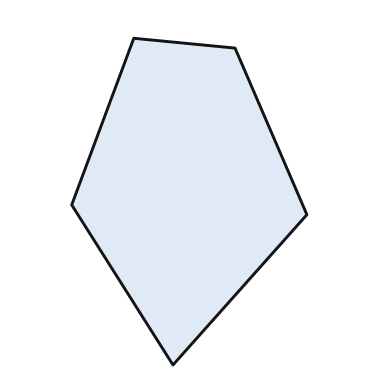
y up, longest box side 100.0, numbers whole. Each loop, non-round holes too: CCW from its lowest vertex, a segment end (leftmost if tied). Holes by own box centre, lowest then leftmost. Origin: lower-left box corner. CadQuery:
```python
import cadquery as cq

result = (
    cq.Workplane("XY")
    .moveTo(31.0, 0.0)
    .lineTo(72.0, 46.0)
    .lineTo(50.0, 97.0)
    .lineTo(19.0, 100.0)
    .lineTo(0.0, 49.0)
    .close()
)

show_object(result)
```